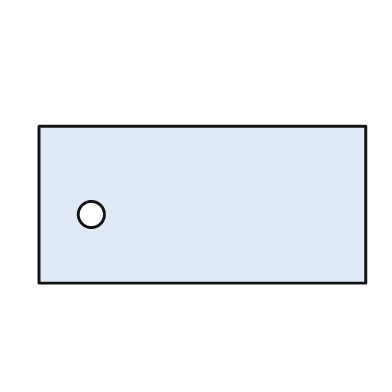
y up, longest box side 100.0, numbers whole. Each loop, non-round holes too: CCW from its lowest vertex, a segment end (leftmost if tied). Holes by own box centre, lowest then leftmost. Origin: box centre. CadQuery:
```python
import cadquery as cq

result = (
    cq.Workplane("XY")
    .moveTo(-50.0, -24.0)
    .lineTo(50.0, -24.0)
    .lineTo(50.0, 24.0)
    .lineTo(-50.0, 24.0)
    .close()
    .moveTo(-34.0, -3.0)
    .circle(4.0)
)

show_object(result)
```